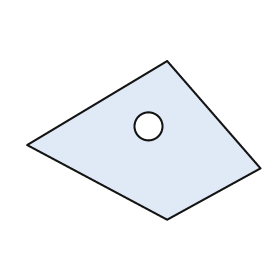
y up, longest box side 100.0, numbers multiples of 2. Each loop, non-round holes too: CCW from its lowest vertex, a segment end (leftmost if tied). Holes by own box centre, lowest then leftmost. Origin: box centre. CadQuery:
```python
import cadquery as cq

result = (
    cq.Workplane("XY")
    .moveTo(10.0, -34.0)
    .lineTo(50.0, -12.0)
    .lineTo(10.0, 34.0)
    .lineTo(-50.0, -2.0)
    .close()
    .moveTo(2.0, 6.0)
    .circle(6.0)
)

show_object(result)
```